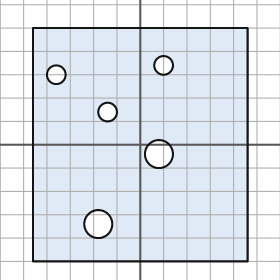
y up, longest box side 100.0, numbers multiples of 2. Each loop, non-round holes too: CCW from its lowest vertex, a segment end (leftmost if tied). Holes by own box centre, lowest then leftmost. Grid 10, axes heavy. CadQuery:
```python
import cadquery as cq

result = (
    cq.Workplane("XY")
    .moveTo(-46.0, -50.0)
    .lineTo(46.0, -50.0)
    .lineTo(46.0, 50.0)
    .lineTo(-46.0, 50.0)
    .close()
    .moveTo(-18.0, -34.0)
    .circle(6.0)
    .moveTo(8.0, -4.0)
    .circle(6.0)
    .moveTo(-14.0, 14.0)
    .circle(4.0)
    .moveTo(-36.0, 30.0)
    .circle(4.0)
    .moveTo(10.0, 34.0)
    .circle(4.0)
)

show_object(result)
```